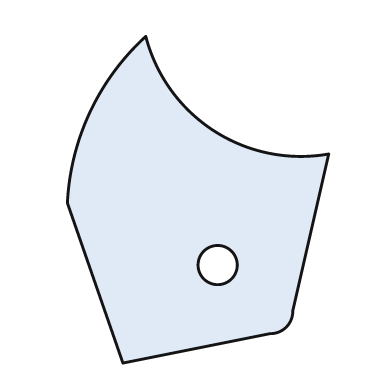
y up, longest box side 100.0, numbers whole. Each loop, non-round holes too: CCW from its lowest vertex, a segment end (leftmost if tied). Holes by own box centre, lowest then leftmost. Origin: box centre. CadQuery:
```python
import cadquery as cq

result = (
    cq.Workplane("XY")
    .moveTo(-23.0, -50.0)
    .lineTo(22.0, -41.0)
    .threePointArc((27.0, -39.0), (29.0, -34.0))
    .lineTo(40.0, 14.0)
    .threePointArc((5.0, 21.0), (-16.0, 50.0))
    .threePointArc((-33.0, 27.0), (-40.0, -1.0))
    .close()
    .moveTo(6.0, -20.0)
    .circle(6.0)
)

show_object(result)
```